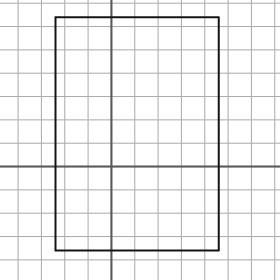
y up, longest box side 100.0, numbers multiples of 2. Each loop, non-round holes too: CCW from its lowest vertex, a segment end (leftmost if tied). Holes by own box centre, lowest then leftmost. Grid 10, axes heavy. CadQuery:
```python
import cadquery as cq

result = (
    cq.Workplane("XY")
    .moveTo(-24.0, -36.0)
    .lineTo(46.0, -36.0)
    .lineTo(46.0, 64.0)
    .lineTo(-24.0, 64.0)
    .close()
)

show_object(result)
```